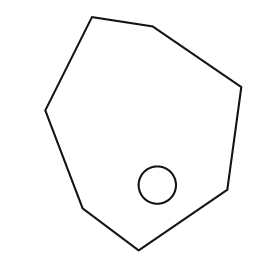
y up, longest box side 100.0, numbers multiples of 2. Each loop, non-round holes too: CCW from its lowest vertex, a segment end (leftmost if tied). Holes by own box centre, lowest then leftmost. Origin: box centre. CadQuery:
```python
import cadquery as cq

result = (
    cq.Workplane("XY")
    .moveTo(-2.0, -50.0)
    .lineTo(36.0, -24.0)
    .lineTo(42.0, 20.0)
    .lineTo(4.0, 46.0)
    .lineTo(-22.0, 50.0)
    .lineTo(-42.0, 10.0)
    .lineTo(-26.0, -32.0)
    .close()
    .moveTo(6.0, -22.0)
    .circle(8.0)
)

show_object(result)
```